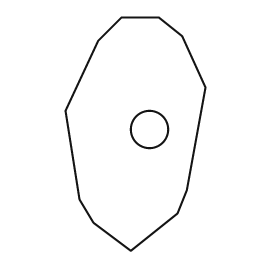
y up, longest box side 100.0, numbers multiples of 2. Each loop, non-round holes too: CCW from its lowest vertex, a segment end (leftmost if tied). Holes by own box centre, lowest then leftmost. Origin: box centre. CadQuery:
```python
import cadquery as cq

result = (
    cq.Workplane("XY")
    .moveTo(-2.0, -50.0)
    .lineTo(18.0, -34.0)
    .lineTo(22.0, -24.0)
    .lineTo(30.0, 20.0)
    .lineTo(20.0, 42.0)
    .lineTo(10.0, 50.0)
    .lineTo(-6.0, 50.0)
    .lineTo(-16.0, 40.0)
    .lineTo(-30.0, 10.0)
    .lineTo(-24.0, -28.0)
    .lineTo(-18.0, -38.0)
    .close()
    .moveTo(6.0, 2.0)
    .circle(8.0)
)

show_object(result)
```